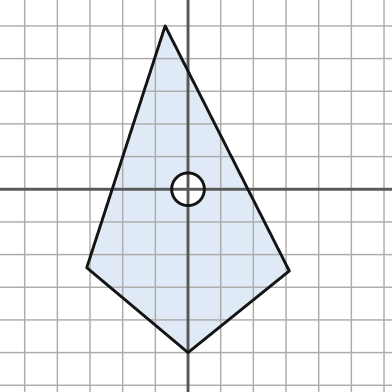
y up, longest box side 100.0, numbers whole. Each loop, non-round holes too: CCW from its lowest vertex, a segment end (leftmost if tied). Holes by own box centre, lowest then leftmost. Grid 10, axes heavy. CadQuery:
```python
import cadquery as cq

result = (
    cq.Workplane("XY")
    .moveTo(0.0, -50.0)
    .lineTo(31.0, -25.0)
    .lineTo(-7.0, 50.0)
    .lineTo(-31.0, -24.0)
    .close()
    .moveTo(0.0, 0.0)
    .circle(5.0)
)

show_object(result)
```